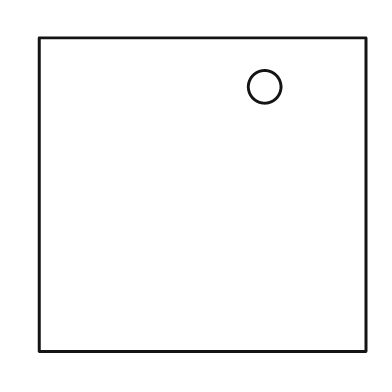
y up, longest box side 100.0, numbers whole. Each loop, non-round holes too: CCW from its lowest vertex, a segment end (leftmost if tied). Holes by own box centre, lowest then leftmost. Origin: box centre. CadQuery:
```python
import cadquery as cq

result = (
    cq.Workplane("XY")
    .moveTo(-50.0, -48.0)
    .lineTo(50.0, -48.0)
    .lineTo(50.0, 48.0)
    .lineTo(-50.0, 48.0)
    .close()
    .moveTo(19.0, 33.0)
    .circle(5.0)
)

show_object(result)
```